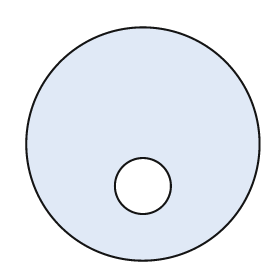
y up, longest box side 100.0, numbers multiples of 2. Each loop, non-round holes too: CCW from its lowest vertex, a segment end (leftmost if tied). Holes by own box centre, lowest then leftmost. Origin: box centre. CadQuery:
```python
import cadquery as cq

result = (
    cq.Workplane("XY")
    .moveTo(0.0, 0.0)
    .circle(50.0)
    .moveTo(0.0, -18.0)
    .circle(12.0)
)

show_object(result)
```